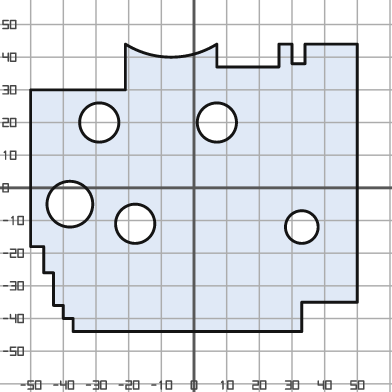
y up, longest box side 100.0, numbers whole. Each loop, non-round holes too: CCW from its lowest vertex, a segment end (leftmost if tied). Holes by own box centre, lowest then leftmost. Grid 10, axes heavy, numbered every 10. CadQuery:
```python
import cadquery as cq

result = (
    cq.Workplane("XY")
    .moveTo(-37.0, -44.0)
    .lineTo(33.0, -44.0)
    .lineTo(33.0, -35.0)
    .lineTo(50.0, -35.0)
    .lineTo(50.0, 44.0)
    .lineTo(34.0, 44.0)
    .lineTo(34.0, 38.0)
    .lineTo(30.0, 38.0)
    .lineTo(30.0, 44.0)
    .lineTo(26.0, 44.0)
    .lineTo(26.0, 37.0)
    .lineTo(7.0, 37.0)
    .lineTo(7.0, 44.0)
    .threePointArc((-7.0, 40.0), (-21.0, 44.0))
    .lineTo(-21.0, 30.0)
    .lineTo(-50.0, 30.0)
    .lineTo(-50.0, -18.0)
    .lineTo(-46.0, -18.0)
    .lineTo(-46.0, -26.0)
    .lineTo(-43.0, -26.0)
    .lineTo(-43.0, -36.0)
    .lineTo(-40.0, -36.0)
    .lineTo(-40.0, -40.0)
    .lineTo(-37.0, -40.0)
    .close()
    .moveTo(33.0, -12.0)
    .circle(5.0)
    .moveTo(-18.0, -11.0)
    .circle(6.0)
    .moveTo(-38.0, -5.0)
    .circle(7.0)
    .moveTo(-29.0, 20.0)
    .circle(6.0)
    .moveTo(7.0, 20.0)
    .circle(6.0)
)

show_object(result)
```